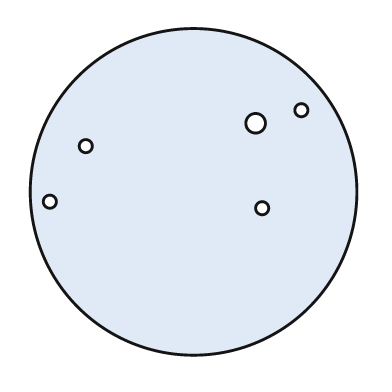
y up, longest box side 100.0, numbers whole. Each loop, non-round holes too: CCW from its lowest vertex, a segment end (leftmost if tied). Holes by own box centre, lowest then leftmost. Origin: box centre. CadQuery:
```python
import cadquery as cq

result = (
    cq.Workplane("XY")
    .moveTo(0.0, 0.0)
    .circle(50.0)
    .moveTo(21.0, -5.0)
    .circle(2.0)
    .moveTo(-44.0, -3.0)
    .circle(2.0)
    .moveTo(-33.0, 14.0)
    .circle(2.0)
    .moveTo(19.0, 21.0)
    .circle(3.0)
    .moveTo(33.0, 25.0)
    .circle(2.0)
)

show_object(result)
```